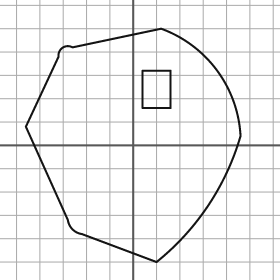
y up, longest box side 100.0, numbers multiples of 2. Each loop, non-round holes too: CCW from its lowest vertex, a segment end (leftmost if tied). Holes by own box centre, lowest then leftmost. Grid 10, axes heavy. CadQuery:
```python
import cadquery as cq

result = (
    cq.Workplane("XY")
    .moveTo(10.0, -50.0)
    .threePointArc((32.0, -26.0), (46.0, 4.0))
    .threePointArc((36.0, 32.0), (12.0, 50.0))
    .lineTo(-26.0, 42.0)
    .threePointArc((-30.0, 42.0), (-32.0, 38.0))
    .lineTo(-46.0, 8.0)
    .lineTo(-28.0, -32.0)
    .threePointArc((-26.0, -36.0), (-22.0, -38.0))
    .close()
    .moveTo(4.0, 16.0)
    .lineTo(16.0, 16.0)
    .lineTo(16.0, 32.0)
    .lineTo(4.0, 32.0)
    .close()
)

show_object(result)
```